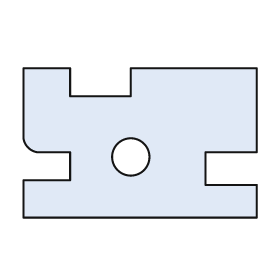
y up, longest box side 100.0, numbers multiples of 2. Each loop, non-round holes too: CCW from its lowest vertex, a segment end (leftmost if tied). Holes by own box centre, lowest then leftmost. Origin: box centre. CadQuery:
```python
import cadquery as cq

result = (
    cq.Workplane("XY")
    .moveTo(-50.0, -32.0)
    .lineTo(50.0, -32.0)
    .lineTo(50.0, -18.0)
    .lineTo(28.0, -18.0)
    .lineTo(28.0, -4.0)
    .lineTo(50.0, -4.0)
    .lineTo(50.0, 32.0)
    .lineTo(-4.0, 32.0)
    .lineTo(-4.0, 20.0)
    .lineTo(-30.0, 20.0)
    .lineTo(-30.0, 32.0)
    .lineTo(-50.0, 32.0)
    .lineTo(-50.0, 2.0)
    .threePointArc((-48.0, -2.0), (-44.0, -4.0))
    .lineTo(-30.0, -4.0)
    .lineTo(-30.0, -16.0)
    .lineTo(-50.0, -16.0)
    .close()
    .moveTo(-4.0, -6.0)
    .circle(8.0)
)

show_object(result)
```